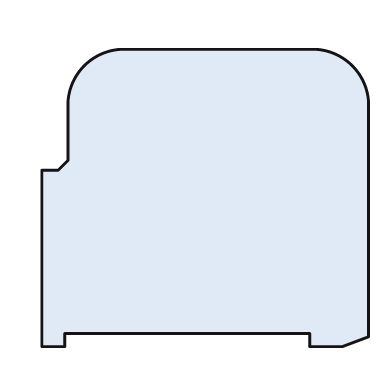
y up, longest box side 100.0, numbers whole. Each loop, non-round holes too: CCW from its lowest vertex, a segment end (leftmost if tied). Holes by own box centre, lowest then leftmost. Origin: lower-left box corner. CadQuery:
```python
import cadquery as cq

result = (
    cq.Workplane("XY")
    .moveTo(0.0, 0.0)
    .lineTo(7.0, 0.0)
    .lineTo(7.0, 4.0)
    .lineTo(82.0, 4.0)
    .lineTo(82.0, 0.0)
    .lineTo(92.0, 0.0)
    .lineTo(100.0, 3.0)
    .lineTo(100.0, 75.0)
    .threePointArc((95.0, 86.0), (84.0, 91.0))
    .lineTo(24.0, 91.0)
    .threePointArc((13.0, 86.0), (8.0, 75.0))
    .lineTo(8.0, 57.0)
    .lineTo(5.0, 54.0)
    .lineTo(0.0, 54.0)
    .close()
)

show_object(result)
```